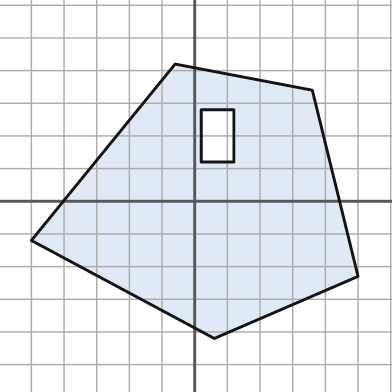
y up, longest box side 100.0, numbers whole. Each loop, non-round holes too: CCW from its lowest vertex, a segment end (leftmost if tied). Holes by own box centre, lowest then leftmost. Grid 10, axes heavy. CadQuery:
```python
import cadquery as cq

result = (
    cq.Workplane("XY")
    .moveTo(6.0, -42.0)
    .lineTo(50.0, -23.0)
    .lineTo(36.0, 34.0)
    .lineTo(-6.0, 42.0)
    .lineTo(-50.0, -12.0)
    .close()
    .moveTo(2.0, 12.0)
    .lineTo(12.0, 12.0)
    .lineTo(12.0, 28.0)
    .lineTo(2.0, 28.0)
    .close()
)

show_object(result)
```